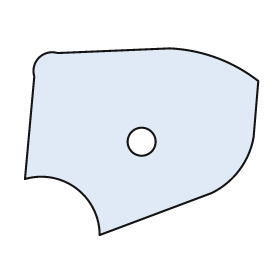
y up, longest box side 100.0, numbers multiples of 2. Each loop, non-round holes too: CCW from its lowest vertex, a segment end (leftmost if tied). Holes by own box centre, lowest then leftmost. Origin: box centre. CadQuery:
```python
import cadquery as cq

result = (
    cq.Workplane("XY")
    .moveTo(-18.0, -40.0)
    .lineTo(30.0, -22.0)
    .threePointArc((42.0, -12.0), (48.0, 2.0))
    .lineTo(50.0, 26.0)
    .threePointArc((32.0, 36.0), (12.0, 40.0))
    .lineTo(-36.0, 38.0)
    .threePointArc((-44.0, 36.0), (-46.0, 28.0))
    .lineTo(-50.0, -16.0)
    .threePointArc((-28.0, -20.0), (-18.0, -40.0))
    .close()
    .moveTo(0.0, 0.0)
    .circle(6.0)
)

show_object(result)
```